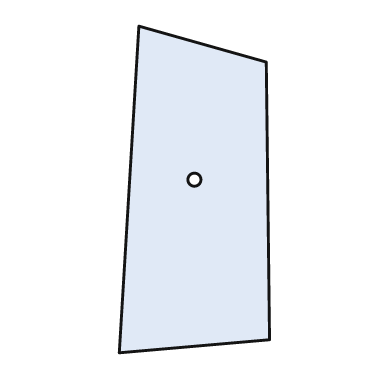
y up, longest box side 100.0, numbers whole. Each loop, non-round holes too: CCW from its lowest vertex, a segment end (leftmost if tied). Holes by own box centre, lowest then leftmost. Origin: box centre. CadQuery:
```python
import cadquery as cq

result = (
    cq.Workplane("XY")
    .moveTo(-23.0, -50.0)
    .lineTo(23.0, -46.0)
    .lineTo(22.0, 39.0)
    .lineTo(-17.0, 50.0)
    .close()
    .moveTo(0.0, 3.0)
    .circle(2.0)
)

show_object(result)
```